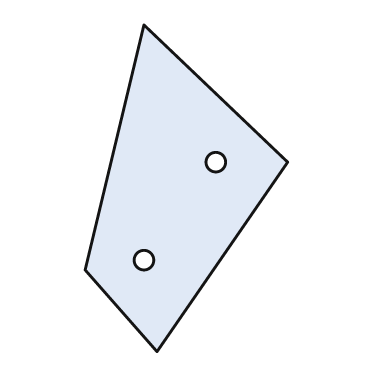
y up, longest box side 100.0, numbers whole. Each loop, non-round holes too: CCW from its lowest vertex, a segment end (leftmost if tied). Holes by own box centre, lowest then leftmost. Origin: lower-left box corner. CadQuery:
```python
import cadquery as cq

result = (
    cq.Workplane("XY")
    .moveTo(22.0, 0.0)
    .lineTo(62.0, 58.0)
    .lineTo(18.0, 100.0)
    .lineTo(0.0, 25.0)
    .close()
    .moveTo(18.0, 28.0)
    .circle(3.0)
    .moveTo(40.0, 58.0)
    .circle(3.0)
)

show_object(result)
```